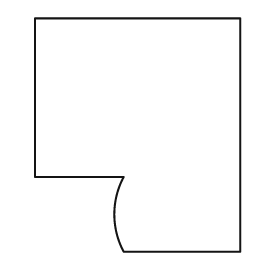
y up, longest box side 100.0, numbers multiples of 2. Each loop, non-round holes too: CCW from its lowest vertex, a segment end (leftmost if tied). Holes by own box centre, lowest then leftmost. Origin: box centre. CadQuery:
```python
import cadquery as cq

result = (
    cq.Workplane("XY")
    .moveTo(-6.0, -50.0)
    .lineTo(44.0, -50.0)
    .lineTo(44.0, 50.0)
    .lineTo(-44.0, 50.0)
    .lineTo(-44.0, -18.0)
    .lineTo(-6.0, -18.0)
    .threePointArc((-10.0, -34.0), (-6.0, -50.0))
    .close()
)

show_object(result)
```